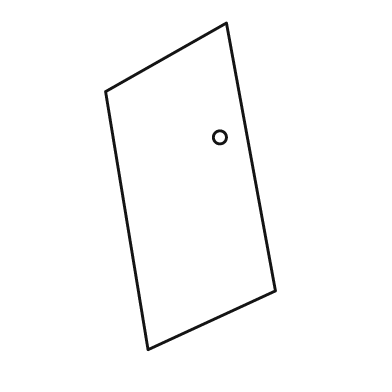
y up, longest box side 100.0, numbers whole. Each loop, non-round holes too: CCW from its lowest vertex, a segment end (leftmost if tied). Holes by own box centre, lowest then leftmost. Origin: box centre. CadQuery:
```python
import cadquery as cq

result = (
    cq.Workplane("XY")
    .moveTo(-13.0, -50.0)
    .lineTo(26.0, -32.0)
    .lineTo(11.0, 50.0)
    .lineTo(-26.0, 29.0)
    .close()
    .moveTo(9.0, 15.0)
    .circle(2.0)
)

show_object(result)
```